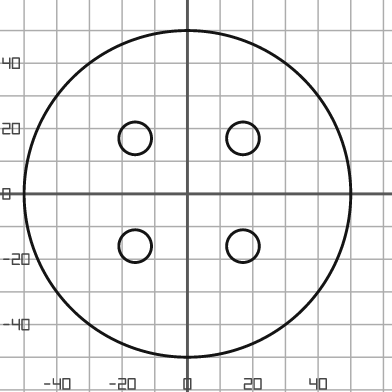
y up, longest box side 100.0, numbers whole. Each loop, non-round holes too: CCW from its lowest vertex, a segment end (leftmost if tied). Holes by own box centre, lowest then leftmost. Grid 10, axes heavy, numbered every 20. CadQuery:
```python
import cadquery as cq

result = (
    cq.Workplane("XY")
    .moveTo(0.0, 0.0)
    .circle(50.0)
    .moveTo(-16.0, -16.0)
    .circle(5.0)
    .moveTo(17.0, -16.0)
    .circle(5.0)
    .moveTo(-16.0, 17.0)
    .circle(5.0)
    .moveTo(17.0, 17.0)
    .circle(5.0)
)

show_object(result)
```